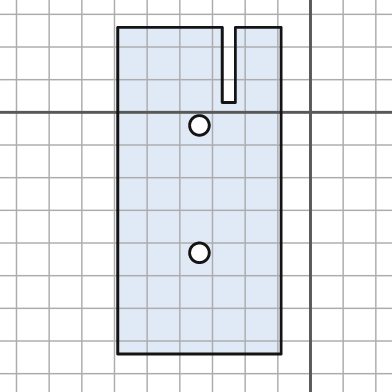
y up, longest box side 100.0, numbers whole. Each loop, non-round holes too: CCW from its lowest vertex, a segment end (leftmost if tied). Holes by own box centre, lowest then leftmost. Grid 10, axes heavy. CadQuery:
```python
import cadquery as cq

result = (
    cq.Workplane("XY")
    .moveTo(-59.0, -74.0)
    .lineTo(-9.0, -74.0)
    .lineTo(-9.0, 26.0)
    .lineTo(-23.0, 26.0)
    .lineTo(-23.0, 3.0)
    .lineTo(-27.0, 3.0)
    .lineTo(-27.0, 26.0)
    .lineTo(-59.0, 26.0)
    .close()
    .moveTo(-34.0, -43.0)
    .circle(3.0)
    .moveTo(-34.0, -4.0)
    .circle(3.0)
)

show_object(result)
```